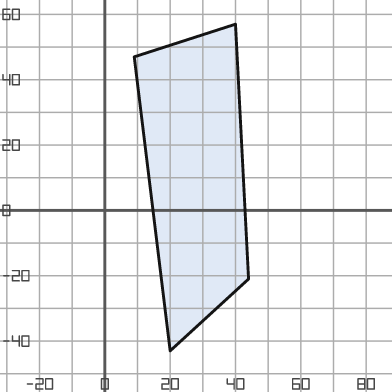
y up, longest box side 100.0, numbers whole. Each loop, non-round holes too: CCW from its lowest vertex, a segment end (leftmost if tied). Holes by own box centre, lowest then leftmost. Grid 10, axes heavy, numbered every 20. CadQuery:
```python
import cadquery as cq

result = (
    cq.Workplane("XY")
    .moveTo(20.0, -43.0)
    .lineTo(44.0, -21.0)
    .lineTo(40.0, 57.0)
    .lineTo(9.0, 47.0)
    .close()
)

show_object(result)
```